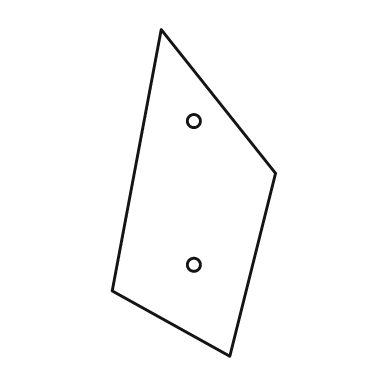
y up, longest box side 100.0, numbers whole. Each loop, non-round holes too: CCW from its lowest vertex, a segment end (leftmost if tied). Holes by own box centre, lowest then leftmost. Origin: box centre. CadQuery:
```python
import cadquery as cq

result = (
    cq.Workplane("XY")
    .moveTo(11.0, -50.0)
    .lineTo(25.0, 6.0)
    .lineTo(-10.0, 50.0)
    .lineTo(-25.0, -30.0)
    .close()
    .moveTo(0.0, -22.0)
    .circle(2.0)
    .moveTo(0.0, 22.0)
    .circle(2.0)
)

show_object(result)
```